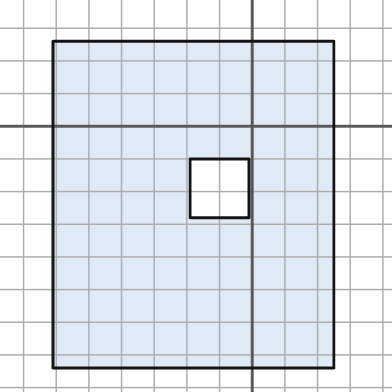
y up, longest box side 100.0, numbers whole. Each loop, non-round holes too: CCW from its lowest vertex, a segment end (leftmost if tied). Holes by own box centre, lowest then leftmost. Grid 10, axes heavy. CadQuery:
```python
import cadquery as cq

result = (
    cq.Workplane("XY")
    .moveTo(-61.0, -74.0)
    .lineTo(25.0, -74.0)
    .lineTo(25.0, 26.0)
    .lineTo(-61.0, 26.0)
    .close()
    .moveTo(-19.0, -28.0)
    .lineTo(-1.0, -28.0)
    .lineTo(-1.0, -10.0)
    .lineTo(-19.0, -10.0)
    .close()
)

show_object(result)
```